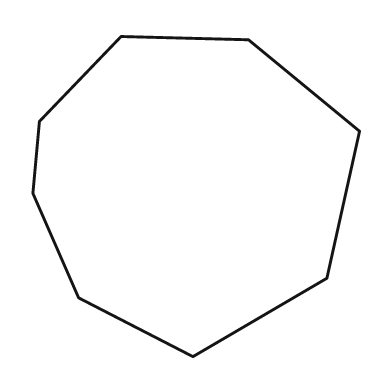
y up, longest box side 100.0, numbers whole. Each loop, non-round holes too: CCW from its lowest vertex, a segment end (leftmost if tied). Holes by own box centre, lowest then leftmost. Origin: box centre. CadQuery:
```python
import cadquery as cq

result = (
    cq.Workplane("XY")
    .moveTo(-1.0, -49.0)
    .lineTo(40.0, -25.0)
    .lineTo(50.0, 20.0)
    .lineTo(16.0, 48.0)
    .lineTo(-23.0, 49.0)
    .lineTo(-48.0, 23.0)
    .lineTo(-50.0, 1.0)
    .lineTo(-36.0, -31.0)
    .close()
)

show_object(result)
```